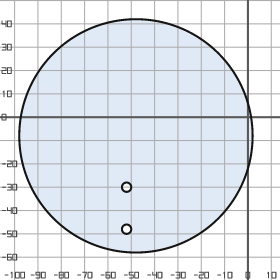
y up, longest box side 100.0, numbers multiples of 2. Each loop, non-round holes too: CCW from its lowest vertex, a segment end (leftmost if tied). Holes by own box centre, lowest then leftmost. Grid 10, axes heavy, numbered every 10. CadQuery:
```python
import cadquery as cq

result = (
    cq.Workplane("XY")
    .moveTo(-48.0, -8.0)
    .circle(50.0)
    .moveTo(-52.0, -48.0)
    .circle(2.0)
    .moveTo(-52.0, -30.0)
    .circle(2.0)
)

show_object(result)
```